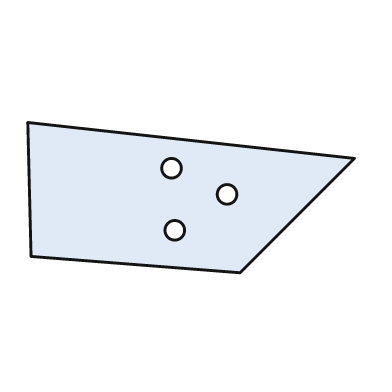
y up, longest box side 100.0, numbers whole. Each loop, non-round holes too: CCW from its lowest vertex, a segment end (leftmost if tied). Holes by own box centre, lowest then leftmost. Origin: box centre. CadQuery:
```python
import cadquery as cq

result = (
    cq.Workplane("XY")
    .moveTo(15.0, -23.0)
    .lineTo(50.0, 12.0)
    .lineTo(-50.0, 23.0)
    .lineTo(-49.0, -18.0)
    .close()
    .moveTo(-5.0, -10.0)
    .circle(3.0)
    .moveTo(11.0, 1.0)
    .circle(3.0)
    .moveTo(-6.0, 9.0)
    .circle(3.0)
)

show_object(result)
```